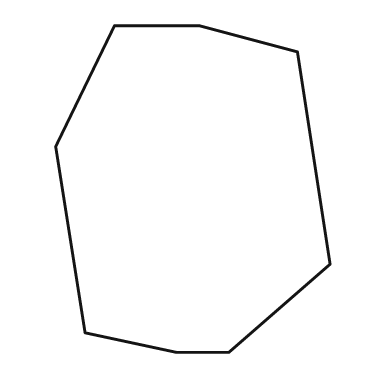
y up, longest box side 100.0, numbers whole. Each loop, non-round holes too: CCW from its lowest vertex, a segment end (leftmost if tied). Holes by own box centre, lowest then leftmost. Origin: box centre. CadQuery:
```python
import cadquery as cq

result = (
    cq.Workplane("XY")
    .moveTo(-5.0, -50.0)
    .lineTo(11.0, -50.0)
    .lineTo(42.0, -23.0)
    .lineTo(32.0, 42.0)
    .lineTo(2.0, 50.0)
    .lineTo(-24.0, 50.0)
    .lineTo(-42.0, 13.0)
    .lineTo(-33.0, -44.0)
    .close()
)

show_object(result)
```